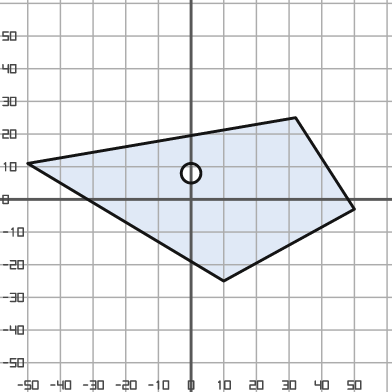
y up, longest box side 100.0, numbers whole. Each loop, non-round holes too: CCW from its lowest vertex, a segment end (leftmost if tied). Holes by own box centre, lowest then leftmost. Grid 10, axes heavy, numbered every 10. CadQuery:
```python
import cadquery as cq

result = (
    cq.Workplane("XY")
    .moveTo(10.0, -25.0)
    .lineTo(50.0, -3.0)
    .lineTo(32.0, 25.0)
    .lineTo(-50.0, 11.0)
    .close()
    .moveTo(0.0, 8.0)
    .circle(3.0)
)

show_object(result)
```